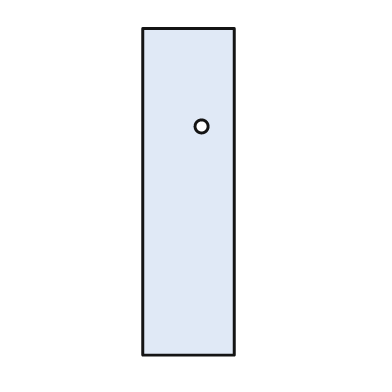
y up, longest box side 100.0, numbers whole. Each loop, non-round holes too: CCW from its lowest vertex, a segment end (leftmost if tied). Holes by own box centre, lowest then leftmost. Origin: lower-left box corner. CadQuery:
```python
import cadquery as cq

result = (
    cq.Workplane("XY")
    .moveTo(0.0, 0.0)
    .lineTo(28.0, 0.0)
    .lineTo(28.0, 100.0)
    .lineTo(0.0, 100.0)
    .close()
    .moveTo(18.0, 70.0)
    .circle(2.0)
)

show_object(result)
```